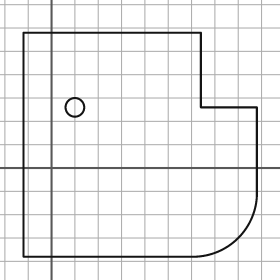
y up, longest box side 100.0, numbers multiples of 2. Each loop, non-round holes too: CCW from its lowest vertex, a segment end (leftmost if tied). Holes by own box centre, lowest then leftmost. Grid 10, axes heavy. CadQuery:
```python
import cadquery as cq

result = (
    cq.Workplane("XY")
    .moveTo(-12.0, -38.0)
    .lineTo(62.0, -38.0)
    .threePointArc((80.0, -30.0), (88.0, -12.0))
    .lineTo(88.0, 26.0)
    .lineTo(64.0, 26.0)
    .lineTo(64.0, 58.0)
    .lineTo(-12.0, 58.0)
    .close()
    .moveTo(10.0, 26.0)
    .circle(4.0)
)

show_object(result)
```